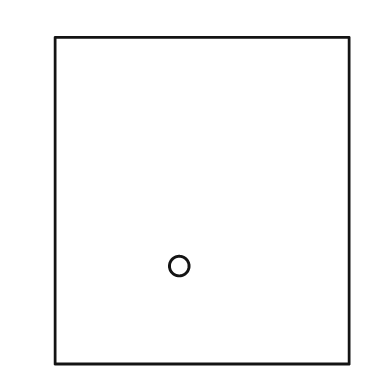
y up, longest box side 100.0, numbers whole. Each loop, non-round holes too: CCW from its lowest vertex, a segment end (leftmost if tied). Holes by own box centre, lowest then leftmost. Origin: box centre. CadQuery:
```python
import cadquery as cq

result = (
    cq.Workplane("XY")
    .moveTo(-45.0, -50.0)
    .lineTo(45.0, -50.0)
    .lineTo(45.0, 50.0)
    .lineTo(-45.0, 50.0)
    .close()
    .moveTo(-7.0, -20.0)
    .circle(3.0)
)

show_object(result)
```